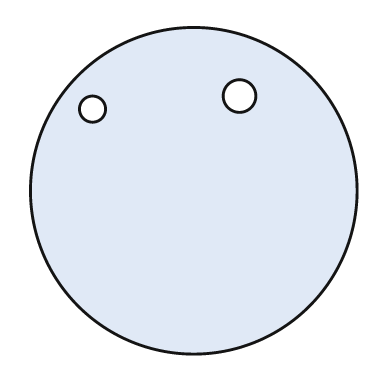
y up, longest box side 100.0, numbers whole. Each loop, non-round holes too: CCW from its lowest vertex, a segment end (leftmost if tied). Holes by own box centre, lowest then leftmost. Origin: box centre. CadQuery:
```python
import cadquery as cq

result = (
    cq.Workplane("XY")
    .moveTo(0.0, 0.0)
    .circle(50.0)
    .moveTo(-31.0, 25.0)
    .circle(4.0)
    .moveTo(14.0, 29.0)
    .circle(5.0)
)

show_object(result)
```